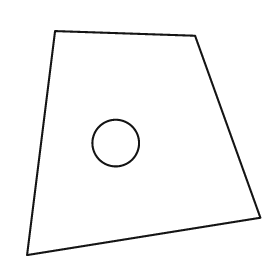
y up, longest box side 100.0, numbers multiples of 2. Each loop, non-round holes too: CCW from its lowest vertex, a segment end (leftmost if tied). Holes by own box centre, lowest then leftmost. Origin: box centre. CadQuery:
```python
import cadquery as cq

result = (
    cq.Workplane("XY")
    .moveTo(-50.0, -48.0)
    .lineTo(50.0, -32.0)
    .lineTo(22.0, 46.0)
    .lineTo(-38.0, 48.0)
    .close()
    .moveTo(-12.0, 0.0)
    .circle(10.0)
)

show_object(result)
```